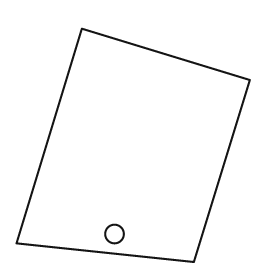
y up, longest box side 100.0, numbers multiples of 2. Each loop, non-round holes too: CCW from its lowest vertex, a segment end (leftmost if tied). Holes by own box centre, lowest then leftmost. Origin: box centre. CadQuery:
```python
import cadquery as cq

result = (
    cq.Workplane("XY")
    .moveTo(26.0, -50.0)
    .lineTo(50.0, 28.0)
    .lineTo(-22.0, 50.0)
    .lineTo(-50.0, -42.0)
    .close()
    .moveTo(-8.0, -38.0)
    .circle(4.0)
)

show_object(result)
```